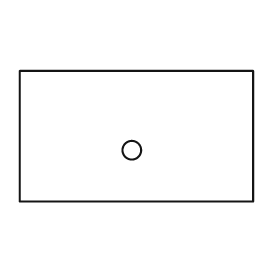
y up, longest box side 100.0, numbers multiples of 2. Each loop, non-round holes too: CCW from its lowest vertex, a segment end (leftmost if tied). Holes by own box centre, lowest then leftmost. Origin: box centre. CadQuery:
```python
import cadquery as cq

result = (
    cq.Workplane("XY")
    .moveTo(-50.0, -28.0)
    .lineTo(50.0, -28.0)
    .lineTo(50.0, 28.0)
    .lineTo(-50.0, 28.0)
    .close()
    .moveTo(-2.0, -6.0)
    .circle(4.0)
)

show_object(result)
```